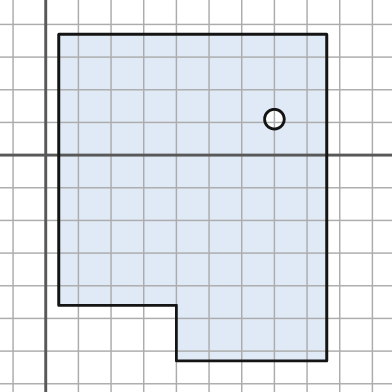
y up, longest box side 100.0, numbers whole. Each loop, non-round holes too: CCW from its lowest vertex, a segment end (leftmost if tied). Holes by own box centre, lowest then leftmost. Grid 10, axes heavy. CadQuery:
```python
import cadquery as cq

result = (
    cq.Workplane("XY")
    .moveTo(40.0, -63.0)
    .lineTo(86.0, -63.0)
    .lineTo(86.0, 37.0)
    .lineTo(4.0, 37.0)
    .lineTo(4.0, -46.0)
    .lineTo(40.0, -46.0)
    .close()
    .moveTo(70.0, 11.0)
    .circle(3.0)
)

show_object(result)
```